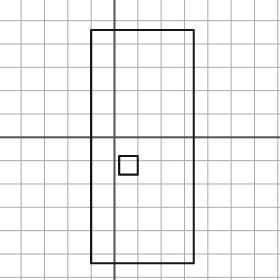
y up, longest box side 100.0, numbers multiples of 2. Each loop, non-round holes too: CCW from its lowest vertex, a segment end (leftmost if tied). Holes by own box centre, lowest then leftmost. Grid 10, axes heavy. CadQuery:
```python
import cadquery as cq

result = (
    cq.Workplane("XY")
    .moveTo(-10.0, -54.0)
    .lineTo(34.0, -54.0)
    .lineTo(34.0, 46.0)
    .lineTo(-10.0, 46.0)
    .close()
    .moveTo(2.0, -16.0)
    .lineTo(10.0, -16.0)
    .lineTo(10.0, -8.0)
    .lineTo(2.0, -8.0)
    .close()
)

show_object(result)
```